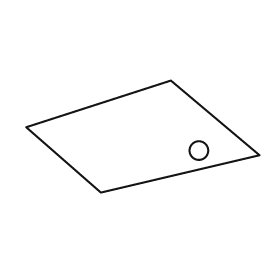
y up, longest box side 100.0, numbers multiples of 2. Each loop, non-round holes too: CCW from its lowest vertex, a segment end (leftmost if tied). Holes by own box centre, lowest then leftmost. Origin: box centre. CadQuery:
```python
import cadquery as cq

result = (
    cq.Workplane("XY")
    .moveTo(-18.0, -24.0)
    .lineTo(50.0, -8.0)
    .lineTo(12.0, 24.0)
    .lineTo(-50.0, 4.0)
    .close()
    .moveTo(24.0, -6.0)
    .circle(4.0)
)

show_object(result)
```